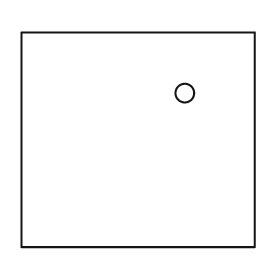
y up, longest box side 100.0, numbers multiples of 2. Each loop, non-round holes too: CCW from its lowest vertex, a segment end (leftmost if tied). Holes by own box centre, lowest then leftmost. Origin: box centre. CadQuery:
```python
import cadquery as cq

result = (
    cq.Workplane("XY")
    .moveTo(-50.0, -46.0)
    .lineTo(50.0, -46.0)
    .lineTo(50.0, 46.0)
    .lineTo(-50.0, 46.0)
    .close()
    .moveTo(20.0, 20.0)
    .circle(4.0)
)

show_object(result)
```